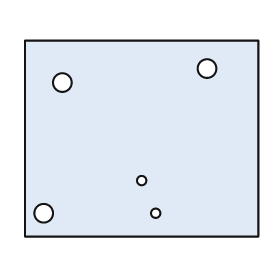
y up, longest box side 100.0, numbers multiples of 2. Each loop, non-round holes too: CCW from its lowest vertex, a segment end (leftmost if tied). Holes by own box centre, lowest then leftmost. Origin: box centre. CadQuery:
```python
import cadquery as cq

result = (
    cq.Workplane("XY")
    .moveTo(-50.0, -42.0)
    .lineTo(50.0, -42.0)
    .lineTo(50.0, 42.0)
    .lineTo(-50.0, 42.0)
    .close()
    .moveTo(-42.0, -32.0)
    .circle(4.0)
    .moveTo(6.0, -32.0)
    .circle(2.0)
    .moveTo(0.0, -18.0)
    .circle(2.0)
    .moveTo(-34.0, 24.0)
    .circle(4.0)
    .moveTo(28.0, 30.0)
    .circle(4.0)
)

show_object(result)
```